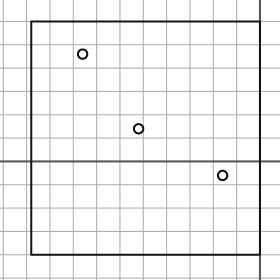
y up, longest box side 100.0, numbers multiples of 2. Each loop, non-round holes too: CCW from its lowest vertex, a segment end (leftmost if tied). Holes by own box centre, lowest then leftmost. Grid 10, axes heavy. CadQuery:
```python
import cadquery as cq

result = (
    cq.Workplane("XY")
    .moveTo(-98.0, -40.0)
    .lineTo(0.0, -40.0)
    .lineTo(0.0, 60.0)
    .lineTo(-98.0, 60.0)
    .close()
    .moveTo(-16.0, -6.0)
    .circle(2.0)
    .moveTo(-52.0, 14.0)
    .circle(2.0)
    .moveTo(-76.0, 46.0)
    .circle(2.0)
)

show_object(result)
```